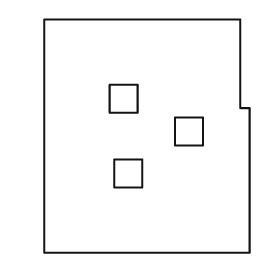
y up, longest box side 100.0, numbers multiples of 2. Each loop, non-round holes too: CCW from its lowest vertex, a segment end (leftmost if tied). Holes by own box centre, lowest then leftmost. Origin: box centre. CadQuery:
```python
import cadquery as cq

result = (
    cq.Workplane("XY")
    .moveTo(-44.0, -50.0)
    .lineTo(44.0, -50.0)
    .lineTo(44.0, 12.0)
    .lineTo(40.0, 12.0)
    .lineTo(40.0, 50.0)
    .lineTo(-44.0, 50.0)
    .close()
    .moveTo(-14.0, -22.0)
    .lineTo(-2.0, -22.0)
    .lineTo(-2.0, -10.0)
    .lineTo(-14.0, -10.0)
    .close()
    .moveTo(12.0, -4.0)
    .lineTo(24.0, -4.0)
    .lineTo(24.0, 8.0)
    .lineTo(12.0, 8.0)
    .close()
    .moveTo(-16.0, 10.0)
    .lineTo(-4.0, 10.0)
    .lineTo(-4.0, 22.0)
    .lineTo(-16.0, 22.0)
    .close()
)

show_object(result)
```